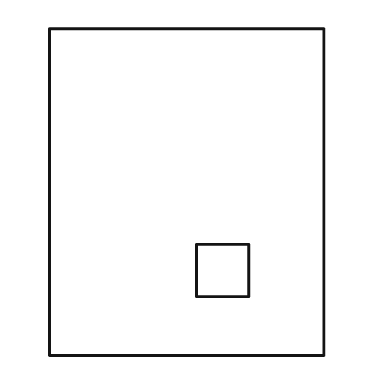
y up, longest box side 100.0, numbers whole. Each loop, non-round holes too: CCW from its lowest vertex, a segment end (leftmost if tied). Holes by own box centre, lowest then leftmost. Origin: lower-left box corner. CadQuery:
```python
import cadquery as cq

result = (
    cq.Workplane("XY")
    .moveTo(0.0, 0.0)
    .lineTo(84.0, 0.0)
    .lineTo(84.0, 100.0)
    .lineTo(0.0, 100.0)
    .close()
    .moveTo(45.0, 18.0)
    .lineTo(61.0, 18.0)
    .lineTo(61.0, 34.0)
    .lineTo(45.0, 34.0)
    .close()
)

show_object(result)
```